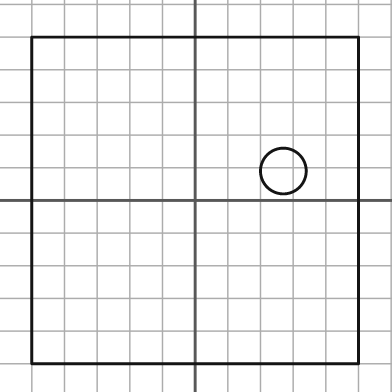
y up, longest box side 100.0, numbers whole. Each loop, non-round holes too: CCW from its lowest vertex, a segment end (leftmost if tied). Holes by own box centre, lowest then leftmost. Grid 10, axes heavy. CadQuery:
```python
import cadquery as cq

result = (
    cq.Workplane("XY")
    .moveTo(-50.0, -50.0)
    .lineTo(50.0, -50.0)
    .lineTo(50.0, 50.0)
    .lineTo(-50.0, 50.0)
    .close()
    .moveTo(27.0, 9.0)
    .circle(7.0)
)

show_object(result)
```